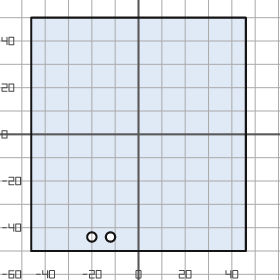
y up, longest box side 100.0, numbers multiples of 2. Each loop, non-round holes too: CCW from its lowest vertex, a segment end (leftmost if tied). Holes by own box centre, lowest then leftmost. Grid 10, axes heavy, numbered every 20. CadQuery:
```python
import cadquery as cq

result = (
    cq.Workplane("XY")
    .moveTo(-46.0, -50.0)
    .lineTo(46.0, -50.0)
    .lineTo(46.0, 50.0)
    .lineTo(-46.0, 50.0)
    .close()
    .moveTo(-20.0, -44.0)
    .circle(2.0)
    .moveTo(-12.0, -44.0)
    .circle(2.0)
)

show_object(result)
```